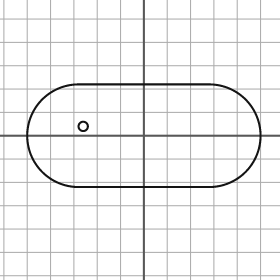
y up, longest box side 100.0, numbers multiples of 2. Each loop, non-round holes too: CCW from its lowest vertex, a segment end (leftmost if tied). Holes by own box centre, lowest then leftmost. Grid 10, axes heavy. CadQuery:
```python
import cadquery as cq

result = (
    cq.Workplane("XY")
    .moveTo(-28.0, -22.0)
    .lineTo(28.0, -22.0)
    .threePointArc((50.0, 0.0), (28.0, 22.0))
    .lineTo(-28.0, 22.0)
    .threePointArc((-50.0, 0.0), (-28.0, -22.0))
    .close()
    .moveTo(-26.0, 4.0)
    .circle(2.0)
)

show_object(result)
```